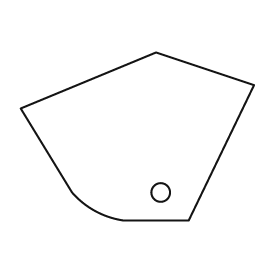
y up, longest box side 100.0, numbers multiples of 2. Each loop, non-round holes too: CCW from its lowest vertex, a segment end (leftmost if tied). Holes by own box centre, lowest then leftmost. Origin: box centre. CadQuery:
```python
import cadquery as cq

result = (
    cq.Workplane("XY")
    .moveTo(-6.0, -36.0)
    .lineTo(22.0, -36.0)
    .lineTo(50.0, 22.0)
    .lineTo(8.0, 36.0)
    .lineTo(-50.0, 12.0)
    .lineTo(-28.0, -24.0)
    .threePointArc((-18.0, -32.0), (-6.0, -36.0))
    .close()
    .moveTo(10.0, -24.0)
    .circle(4.0)
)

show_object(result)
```